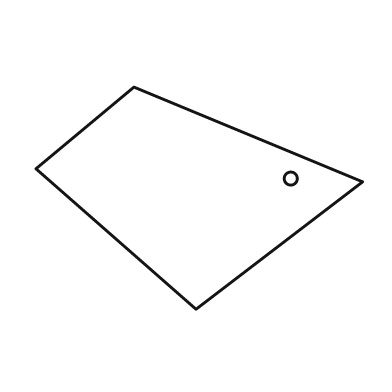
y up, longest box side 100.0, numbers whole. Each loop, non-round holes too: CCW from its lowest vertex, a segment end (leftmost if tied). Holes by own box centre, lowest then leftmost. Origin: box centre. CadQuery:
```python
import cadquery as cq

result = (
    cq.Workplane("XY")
    .moveTo(-1.0, -34.0)
    .lineTo(50.0, 5.0)
    .lineTo(-20.0, 34.0)
    .lineTo(-50.0, 9.0)
    .close()
    .moveTo(28.0, 6.0)
    .circle(2.0)
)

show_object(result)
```